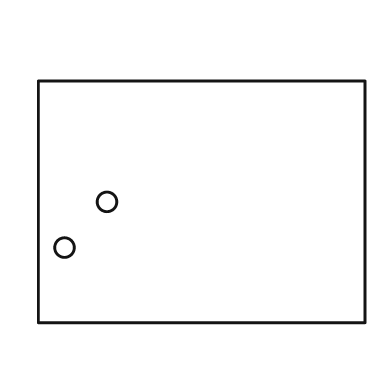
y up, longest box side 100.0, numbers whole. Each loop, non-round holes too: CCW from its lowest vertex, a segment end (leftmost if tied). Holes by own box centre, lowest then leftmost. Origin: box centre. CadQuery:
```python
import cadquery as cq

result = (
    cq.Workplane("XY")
    .moveTo(-50.0, -37.0)
    .lineTo(50.0, -37.0)
    .lineTo(50.0, 37.0)
    .lineTo(-50.0, 37.0)
    .close()
    .moveTo(-42.0, -14.0)
    .circle(3.0)
    .moveTo(-29.0, 0.0)
    .circle(3.0)
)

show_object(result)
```